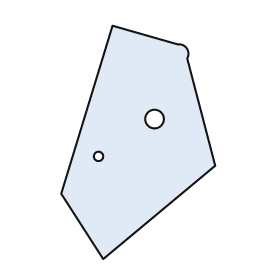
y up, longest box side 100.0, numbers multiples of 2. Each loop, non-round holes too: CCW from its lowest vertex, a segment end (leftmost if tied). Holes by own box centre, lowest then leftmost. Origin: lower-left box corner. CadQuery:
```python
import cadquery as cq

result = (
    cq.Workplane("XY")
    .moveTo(18.0, 0.0)
    .lineTo(66.0, 40.0)
    .lineTo(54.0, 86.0)
    .threePointArc((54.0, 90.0), (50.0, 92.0))
    .lineTo(22.0, 100.0)
    .lineTo(0.0, 28.0)
    .close()
    .moveTo(16.0, 44.0)
    .circle(2.0)
    .moveTo(40.0, 60.0)
    .circle(4.0)
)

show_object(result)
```